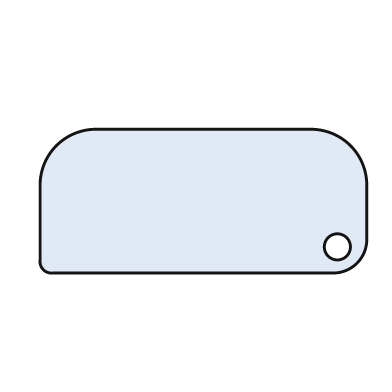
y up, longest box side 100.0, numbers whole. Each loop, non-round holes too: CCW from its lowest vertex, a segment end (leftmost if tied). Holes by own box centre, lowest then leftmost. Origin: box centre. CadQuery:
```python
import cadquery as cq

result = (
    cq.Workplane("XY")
    .moveTo(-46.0, -22.0)
    .lineTo(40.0, -22.0)
    .threePointArc((47.0, -19.0), (50.0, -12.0))
    .lineTo(50.0, 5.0)
    .threePointArc((45.0, 17.0), (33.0, 22.0))
    .lineTo(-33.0, 22.0)
    .threePointArc((-45.0, 17.0), (-50.0, 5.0))
    .lineTo(-50.0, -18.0)
    .threePointArc((-49.0, -21.0), (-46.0, -22.0))
    .close()
    .moveTo(41.0, -14.0)
    .circle(4.0)
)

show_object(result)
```